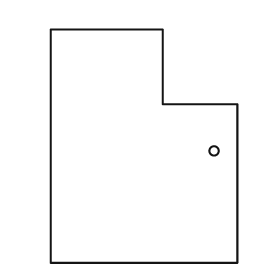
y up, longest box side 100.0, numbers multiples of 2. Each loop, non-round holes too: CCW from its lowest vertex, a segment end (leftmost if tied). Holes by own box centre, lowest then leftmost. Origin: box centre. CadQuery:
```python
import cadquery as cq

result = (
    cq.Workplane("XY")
    .moveTo(-40.0, -50.0)
    .lineTo(40.0, -50.0)
    .lineTo(40.0, 18.0)
    .lineTo(8.0, 18.0)
    .lineTo(8.0, 50.0)
    .lineTo(-40.0, 50.0)
    .close()
    .moveTo(30.0, -2.0)
    .circle(2.0)
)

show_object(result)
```